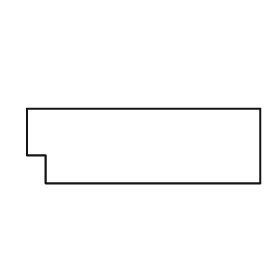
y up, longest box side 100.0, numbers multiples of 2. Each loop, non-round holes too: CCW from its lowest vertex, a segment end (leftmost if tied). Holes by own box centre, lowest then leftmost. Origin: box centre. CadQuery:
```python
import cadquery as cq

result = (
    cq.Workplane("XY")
    .moveTo(-42.0, -16.0)
    .lineTo(50.0, -16.0)
    .lineTo(50.0, 16.0)
    .lineTo(-50.0, 16.0)
    .lineTo(-50.0, -4.0)
    .lineTo(-42.0, -4.0)
    .close()
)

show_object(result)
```